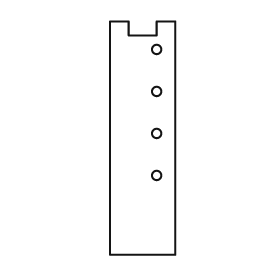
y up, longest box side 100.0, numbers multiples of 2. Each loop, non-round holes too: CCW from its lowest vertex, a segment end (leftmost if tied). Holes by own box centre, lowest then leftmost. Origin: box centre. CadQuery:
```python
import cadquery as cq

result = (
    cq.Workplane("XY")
    .moveTo(-14.0, -50.0)
    .lineTo(14.0, -50.0)
    .lineTo(14.0, 50.0)
    .lineTo(6.0, 50.0)
    .lineTo(6.0, 44.0)
    .lineTo(-6.0, 44.0)
    .lineTo(-6.0, 50.0)
    .lineTo(-14.0, 50.0)
    .close()
    .moveTo(6.0, -16.0)
    .circle(2.0)
    .moveTo(6.0, 2.0)
    .circle(2.0)
    .moveTo(6.0, 20.0)
    .circle(2.0)
    .moveTo(6.0, 38.0)
    .circle(2.0)
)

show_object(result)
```